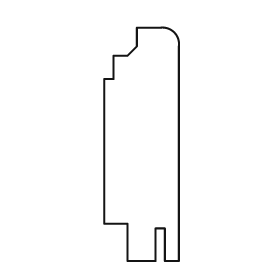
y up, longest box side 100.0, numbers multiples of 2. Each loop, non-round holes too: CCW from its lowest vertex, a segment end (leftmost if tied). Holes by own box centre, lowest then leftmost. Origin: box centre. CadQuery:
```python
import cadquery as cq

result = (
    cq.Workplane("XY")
    .moveTo(-6.0, -50.0)
    .lineTo(6.0, -50.0)
    .lineTo(6.0, -36.0)
    .lineTo(10.0, -36.0)
    .lineTo(10.0, -50.0)
    .lineTo(16.0, -50.0)
    .lineTo(16.0, 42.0)
    .threePointArc((14.0, 48.0), (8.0, 50.0))
    .lineTo(-2.0, 50.0)
    .lineTo(-2.0, 42.0)
    .lineTo(-6.0, 38.0)
    .lineTo(-12.0, 38.0)
    .lineTo(-12.0, 28.0)
    .lineTo(-16.0, 28.0)
    .lineTo(-16.0, -34.0)
    .lineTo(-6.0, -34.0)
    .close()
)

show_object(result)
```